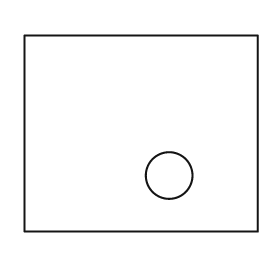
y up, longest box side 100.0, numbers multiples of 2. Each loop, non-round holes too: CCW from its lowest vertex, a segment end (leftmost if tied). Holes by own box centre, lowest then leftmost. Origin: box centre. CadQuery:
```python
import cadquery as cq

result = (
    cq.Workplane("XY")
    .moveTo(-50.0, -42.0)
    .lineTo(50.0, -42.0)
    .lineTo(50.0, 42.0)
    .lineTo(-50.0, 42.0)
    .close()
    .moveTo(12.0, -18.0)
    .circle(10.0)
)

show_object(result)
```